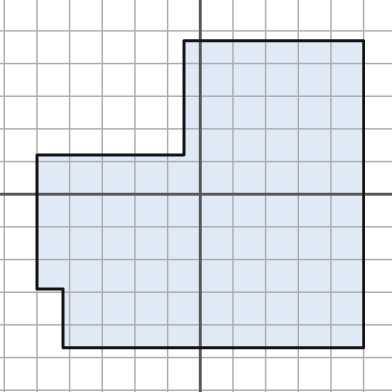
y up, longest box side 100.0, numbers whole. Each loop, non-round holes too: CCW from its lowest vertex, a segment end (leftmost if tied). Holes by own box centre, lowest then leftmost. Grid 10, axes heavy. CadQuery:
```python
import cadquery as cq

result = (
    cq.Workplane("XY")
    .moveTo(-42.0, -47.0)
    .lineTo(50.0, -47.0)
    .lineTo(50.0, 47.0)
    .lineTo(-5.0, 47.0)
    .lineTo(-5.0, 12.0)
    .lineTo(-50.0, 12.0)
    .lineTo(-50.0, -29.0)
    .lineTo(-42.0, -29.0)
    .close()
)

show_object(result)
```